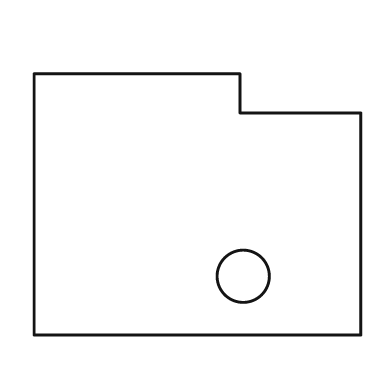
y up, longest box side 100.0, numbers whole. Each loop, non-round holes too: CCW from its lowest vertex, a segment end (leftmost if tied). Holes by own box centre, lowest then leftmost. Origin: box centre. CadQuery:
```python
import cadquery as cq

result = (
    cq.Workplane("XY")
    .moveTo(-50.0, -40.0)
    .lineTo(50.0, -40.0)
    .lineTo(50.0, 28.0)
    .lineTo(13.0, 28.0)
    .lineTo(13.0, 40.0)
    .lineTo(-50.0, 40.0)
    .close()
    .moveTo(14.0, -22.0)
    .circle(8.0)
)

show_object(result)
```